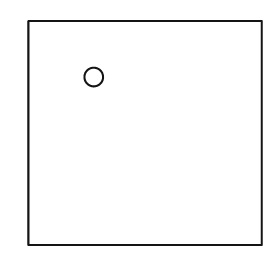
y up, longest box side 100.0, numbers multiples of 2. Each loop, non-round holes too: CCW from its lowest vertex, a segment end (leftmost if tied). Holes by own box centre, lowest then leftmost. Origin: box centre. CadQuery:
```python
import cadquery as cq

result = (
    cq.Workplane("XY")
    .moveTo(-50.0, -48.0)
    .lineTo(50.0, -48.0)
    .lineTo(50.0, 48.0)
    .lineTo(-50.0, 48.0)
    .close()
    .moveTo(-22.0, 24.0)
    .circle(4.0)
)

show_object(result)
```